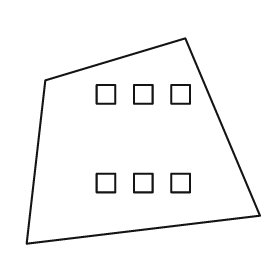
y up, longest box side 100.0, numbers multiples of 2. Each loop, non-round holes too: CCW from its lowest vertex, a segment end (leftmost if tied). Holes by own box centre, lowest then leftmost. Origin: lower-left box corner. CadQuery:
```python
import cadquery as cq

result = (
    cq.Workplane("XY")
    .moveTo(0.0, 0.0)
    .lineTo(100.0, 12.0)
    .lineTo(68.0, 88.0)
    .lineTo(8.0, 70.0)
    .close()
    .moveTo(30.0, 22.0)
    .lineTo(38.0, 22.0)
    .lineTo(38.0, 30.0)
    .lineTo(30.0, 30.0)
    .close()
    .moveTo(46.0, 22.0)
    .lineTo(54.0, 22.0)
    .lineTo(54.0, 30.0)
    .lineTo(46.0, 30.0)
    .close()
    .moveTo(62.0, 22.0)
    .lineTo(70.0, 22.0)
    .lineTo(70.0, 30.0)
    .lineTo(62.0, 30.0)
    .close()
    .moveTo(30.0, 60.0)
    .lineTo(38.0, 60.0)
    .lineTo(38.0, 68.0)
    .lineTo(30.0, 68.0)
    .close()
    .moveTo(46.0, 60.0)
    .lineTo(54.0, 60.0)
    .lineTo(54.0, 68.0)
    .lineTo(46.0, 68.0)
    .close()
    .moveTo(62.0, 60.0)
    .lineTo(70.0, 60.0)
    .lineTo(70.0, 68.0)
    .lineTo(62.0, 68.0)
    .close()
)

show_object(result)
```